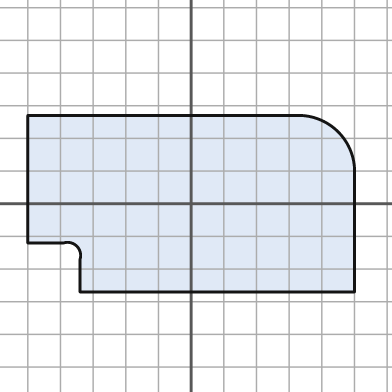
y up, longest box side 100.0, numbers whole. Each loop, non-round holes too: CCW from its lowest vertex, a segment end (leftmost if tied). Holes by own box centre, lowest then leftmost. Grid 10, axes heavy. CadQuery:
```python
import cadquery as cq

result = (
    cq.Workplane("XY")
    .moveTo(-34.0, -27.0)
    .lineTo(50.0, -27.0)
    .lineTo(50.0, 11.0)
    .threePointArc((45.0, 22.0), (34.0, 27.0))
    .lineTo(-50.0, 27.0)
    .lineTo(-50.0, -12.0)
    .lineTo(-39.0, -12.0)
    .threePointArc((-35.0, -13.0), (-34.0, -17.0))
    .close()
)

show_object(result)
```